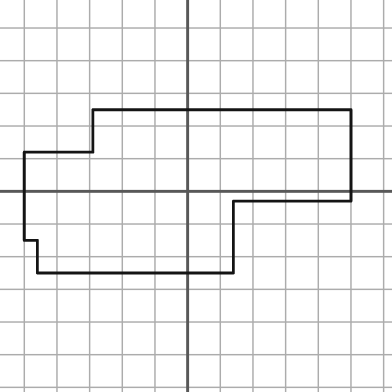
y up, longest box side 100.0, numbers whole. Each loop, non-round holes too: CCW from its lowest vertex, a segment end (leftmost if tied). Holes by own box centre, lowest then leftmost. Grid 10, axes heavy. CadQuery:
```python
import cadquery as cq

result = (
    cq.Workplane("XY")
    .moveTo(-46.0, -25.0)
    .lineTo(14.0, -25.0)
    .lineTo(14.0, -3.0)
    .lineTo(50.0, -3.0)
    .lineTo(50.0, 25.0)
    .lineTo(-29.0, 25.0)
    .lineTo(-29.0, 12.0)
    .lineTo(-50.0, 12.0)
    .lineTo(-50.0, -15.0)
    .lineTo(-46.0, -15.0)
    .close()
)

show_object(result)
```